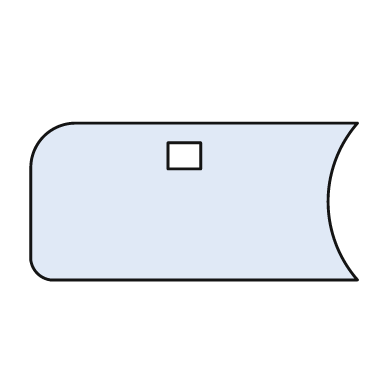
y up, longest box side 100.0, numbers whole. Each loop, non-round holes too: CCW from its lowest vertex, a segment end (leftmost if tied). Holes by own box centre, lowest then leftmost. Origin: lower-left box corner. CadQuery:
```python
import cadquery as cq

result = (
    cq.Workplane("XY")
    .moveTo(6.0, 0.0)
    .lineTo(100.0, 0.0)
    .threePointArc((91.0, 24.0), (100.0, 48.0))
    .lineTo(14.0, 48.0)
    .threePointArc((4.0, 44.0), (0.0, 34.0))
    .lineTo(0.0, 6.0)
    .threePointArc((2.0, 2.0), (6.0, 0.0))
    .close()
    .moveTo(42.0, 34.0)
    .lineTo(52.0, 34.0)
    .lineTo(52.0, 42.0)
    .lineTo(42.0, 42.0)
    .close()
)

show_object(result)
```